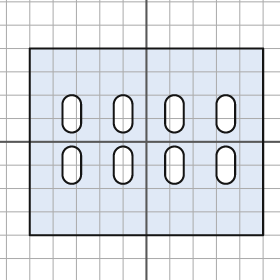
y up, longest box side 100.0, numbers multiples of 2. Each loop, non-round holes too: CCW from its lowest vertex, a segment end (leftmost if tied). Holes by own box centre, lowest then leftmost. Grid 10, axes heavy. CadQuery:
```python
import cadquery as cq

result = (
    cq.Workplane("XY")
    .moveTo(-50.0, -40.0)
    .lineTo(50.0, -40.0)
    .lineTo(50.0, 40.0)
    .lineTo(-50.0, 40.0)
    .close()
    .moveTo(-36.0, -14.0)
    .threePointArc((-32.0, -18.0), (-28.0, -14.0))
    .lineTo(-28.0, -6.0)
    .threePointArc((-32.0, -2.0), (-36.0, -6.0))
    .close()
    .moveTo(-14.0, -14.0)
    .threePointArc((-10.0, -18.0), (-6.0, -14.0))
    .lineTo(-6.0, -6.0)
    .threePointArc((-10.0, -2.0), (-14.0, -6.0))
    .close()
    .moveTo(8.0, -14.0)
    .threePointArc((12.0, -18.0), (16.0, -14.0))
    .lineTo(16.0, -6.0)
    .threePointArc((12.0, -2.0), (8.0, -6.0))
    .close()
    .moveTo(30.0, -14.0)
    .threePointArc((34.0, -18.0), (38.0, -14.0))
    .lineTo(38.0, -6.0)
    .threePointArc((34.0, -2.0), (30.0, -6.0))
    .close()
    .moveTo(-36.0, 8.0)
    .threePointArc((-32.0, 4.0), (-28.0, 8.0))
    .lineTo(-28.0, 16.0)
    .threePointArc((-32.0, 20.0), (-36.0, 16.0))
    .close()
    .moveTo(-14.0, 8.0)
    .threePointArc((-10.0, 4.0), (-6.0, 8.0))
    .lineTo(-6.0, 16.0)
    .threePointArc((-10.0, 20.0), (-14.0, 16.0))
    .close()
    .moveTo(8.0, 8.0)
    .threePointArc((12.0, 4.0), (16.0, 8.0))
    .lineTo(16.0, 16.0)
    .threePointArc((12.0, 20.0), (8.0, 16.0))
    .close()
    .moveTo(30.0, 8.0)
    .threePointArc((34.0, 4.0), (38.0, 8.0))
    .lineTo(38.0, 16.0)
    .threePointArc((34.0, 20.0), (30.0, 16.0))
    .close()
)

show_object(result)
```